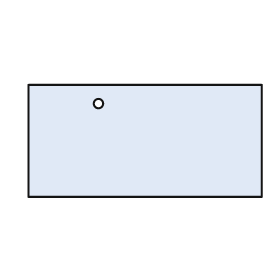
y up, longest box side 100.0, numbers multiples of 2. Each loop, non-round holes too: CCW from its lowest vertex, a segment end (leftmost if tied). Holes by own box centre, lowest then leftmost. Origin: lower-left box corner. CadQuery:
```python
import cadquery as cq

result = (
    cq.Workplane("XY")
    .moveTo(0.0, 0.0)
    .lineTo(100.0, 0.0)
    .lineTo(100.0, 48.0)
    .lineTo(0.0, 48.0)
    .close()
    .moveTo(30.0, 40.0)
    .circle(2.0)
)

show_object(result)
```